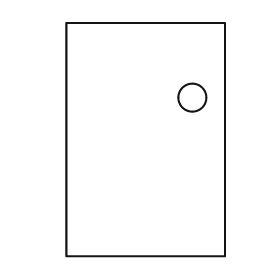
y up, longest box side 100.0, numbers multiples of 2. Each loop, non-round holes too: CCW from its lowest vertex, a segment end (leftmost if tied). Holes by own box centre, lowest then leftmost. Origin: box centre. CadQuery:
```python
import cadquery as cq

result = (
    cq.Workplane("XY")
    .moveTo(-34.0, -50.0)
    .lineTo(34.0, -50.0)
    .lineTo(34.0, 50.0)
    .lineTo(-34.0, 50.0)
    .close()
    .moveTo(20.0, 18.0)
    .circle(6.0)
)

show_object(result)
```